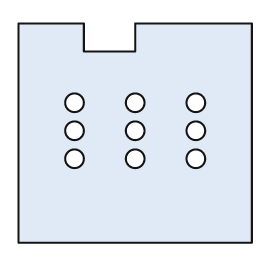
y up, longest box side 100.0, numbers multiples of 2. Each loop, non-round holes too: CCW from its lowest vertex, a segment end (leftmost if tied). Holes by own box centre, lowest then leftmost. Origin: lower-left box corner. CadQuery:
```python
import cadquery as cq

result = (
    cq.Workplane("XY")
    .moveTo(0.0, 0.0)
    .lineTo(100.0, 0.0)
    .lineTo(100.0, 94.0)
    .lineTo(50.0, 94.0)
    .lineTo(50.0, 82.0)
    .lineTo(28.0, 82.0)
    .lineTo(28.0, 94.0)
    .lineTo(0.0, 94.0)
    .close()
    .moveTo(24.0, 36.0)
    .circle(4.0)
    .moveTo(50.0, 36.0)
    .circle(4.0)
    .moveTo(76.0, 36.0)
    .circle(4.0)
    .moveTo(24.0, 48.0)
    .circle(4.0)
    .moveTo(50.0, 48.0)
    .circle(4.0)
    .moveTo(76.0, 48.0)
    .circle(4.0)
    .moveTo(24.0, 60.0)
    .circle(4.0)
    .moveTo(50.0, 60.0)
    .circle(4.0)
    .moveTo(76.0, 60.0)
    .circle(4.0)
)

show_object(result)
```